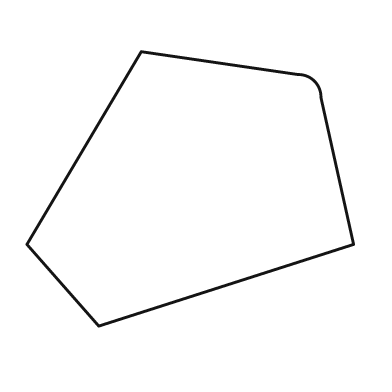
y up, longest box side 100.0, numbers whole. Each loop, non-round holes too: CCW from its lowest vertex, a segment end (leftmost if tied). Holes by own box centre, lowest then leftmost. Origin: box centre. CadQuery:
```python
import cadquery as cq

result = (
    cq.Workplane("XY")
    .moveTo(-28.0, -42.0)
    .lineTo(50.0, -17.0)
    .lineTo(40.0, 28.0)
    .threePointArc((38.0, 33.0), (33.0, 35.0))
    .lineTo(-15.0, 42.0)
    .lineTo(-50.0, -17.0)
    .close()
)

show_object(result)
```